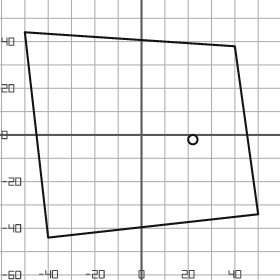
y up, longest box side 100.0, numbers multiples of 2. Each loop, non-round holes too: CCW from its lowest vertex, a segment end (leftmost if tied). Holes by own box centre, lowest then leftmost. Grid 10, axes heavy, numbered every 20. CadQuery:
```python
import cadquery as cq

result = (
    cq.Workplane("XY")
    .moveTo(-40.0, -44.0)
    .lineTo(50.0, -34.0)
    .lineTo(40.0, 38.0)
    .lineTo(-50.0, 44.0)
    .close()
    .moveTo(22.0, -2.0)
    .circle(2.0)
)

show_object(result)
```